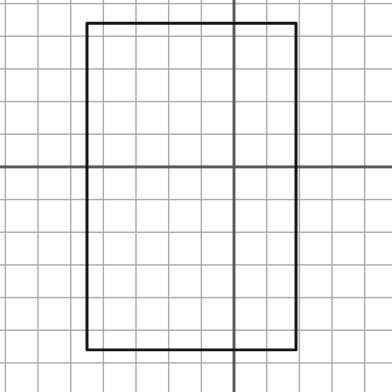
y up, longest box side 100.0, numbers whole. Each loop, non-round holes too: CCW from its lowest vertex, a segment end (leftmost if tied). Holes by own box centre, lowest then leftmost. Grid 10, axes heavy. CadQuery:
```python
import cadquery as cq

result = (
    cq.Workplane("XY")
    .moveTo(-45.0, -56.0)
    .lineTo(19.0, -56.0)
    .lineTo(19.0, 44.0)
    .lineTo(-45.0, 44.0)
    .close()
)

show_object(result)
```